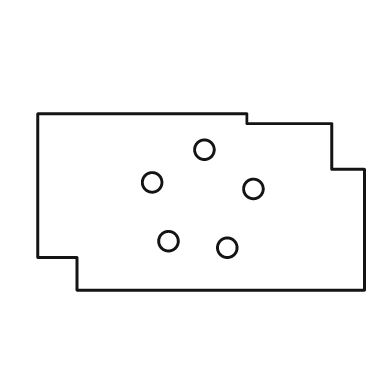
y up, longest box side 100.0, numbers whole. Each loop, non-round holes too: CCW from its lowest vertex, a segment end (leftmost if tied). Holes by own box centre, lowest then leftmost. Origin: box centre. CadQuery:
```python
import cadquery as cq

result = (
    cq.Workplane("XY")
    .moveTo(-38.0, -27.0)
    .lineTo(50.0, -27.0)
    .lineTo(50.0, 10.0)
    .lineTo(40.0, 10.0)
    .lineTo(40.0, 24.0)
    .lineTo(14.0, 24.0)
    .lineTo(14.0, 27.0)
    .lineTo(-50.0, 27.0)
    .lineTo(-50.0, -17.0)
    .lineTo(-38.0, -17.0)
    .close()
    .moveTo(8.0, -14.0)
    .circle(3.0)
    .moveTo(-10.0, -12.0)
    .circle(3.0)
    .moveTo(16.0, 4.0)
    .circle(3.0)
    .moveTo(-15.0, 6.0)
    .circle(3.0)
    .moveTo(1.0, 16.0)
    .circle(3.0)
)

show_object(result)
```